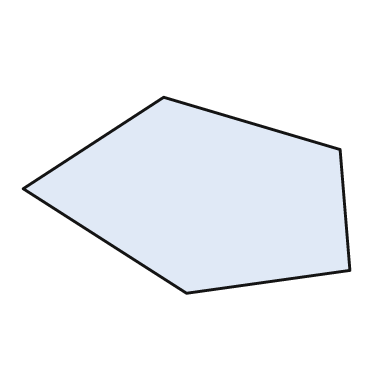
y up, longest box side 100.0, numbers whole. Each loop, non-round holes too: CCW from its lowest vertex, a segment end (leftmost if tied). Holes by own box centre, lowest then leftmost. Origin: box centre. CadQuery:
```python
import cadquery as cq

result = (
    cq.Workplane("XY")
    .moveTo(0.0, -30.0)
    .lineTo(50.0, -23.0)
    .lineTo(47.0, 14.0)
    .lineTo(-7.0, 30.0)
    .lineTo(-50.0, 2.0)
    .close()
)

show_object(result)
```